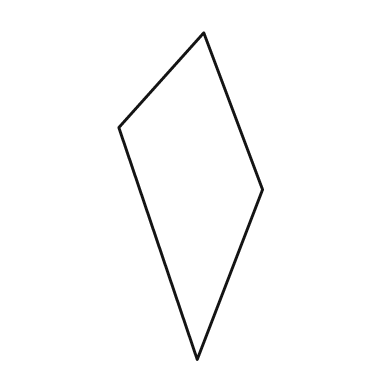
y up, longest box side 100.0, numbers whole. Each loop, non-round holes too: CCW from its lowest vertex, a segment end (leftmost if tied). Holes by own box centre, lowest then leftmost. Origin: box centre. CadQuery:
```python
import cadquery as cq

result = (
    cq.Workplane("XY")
    .moveTo(2.0, -50.0)
    .lineTo(22.0, 2.0)
    .lineTo(4.0, 50.0)
    .lineTo(-22.0, 21.0)
    .close()
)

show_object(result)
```